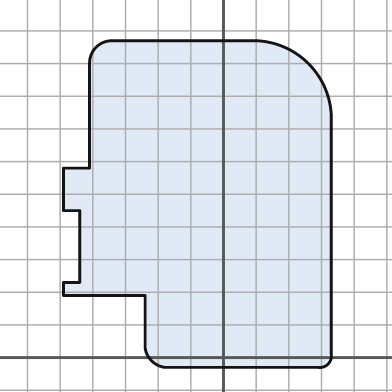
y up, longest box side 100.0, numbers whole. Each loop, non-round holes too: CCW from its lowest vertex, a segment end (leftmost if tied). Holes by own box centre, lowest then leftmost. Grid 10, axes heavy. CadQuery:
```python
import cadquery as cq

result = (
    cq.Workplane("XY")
    .moveTo(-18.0, -3.0)
    .lineTo(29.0, -3.0)
    .threePointArc((32.0, -2.0), (33.0, 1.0))
    .lineTo(33.0, 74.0)
    .threePointArc((26.0, 90.0), (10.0, 97.0))
    .lineTo(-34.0, 97.0)
    .threePointArc((-39.0, 95.0), (-41.0, 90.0))
    .lineTo(-41.0, 58.0)
    .lineTo(-49.0, 58.0)
    .lineTo(-49.0, 45.0)
    .lineTo(-44.0, 45.0)
    .lineTo(-44.0, 23.0)
    .lineTo(-49.0, 23.0)
    .lineTo(-49.0, 19.0)
    .lineTo(-24.0, 19.0)
    .lineTo(-24.0, 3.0)
    .threePointArc((-22.0, -1.0), (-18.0, -3.0))
    .close()
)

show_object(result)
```